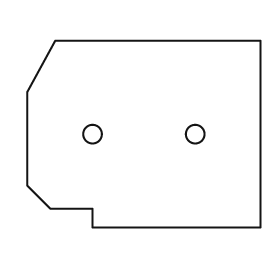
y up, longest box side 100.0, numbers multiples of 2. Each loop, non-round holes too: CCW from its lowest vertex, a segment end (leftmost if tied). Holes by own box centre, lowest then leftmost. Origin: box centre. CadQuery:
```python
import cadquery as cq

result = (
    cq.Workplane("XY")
    .moveTo(-22.0, -40.0)
    .lineTo(50.0, -40.0)
    .lineTo(50.0, 40.0)
    .lineTo(-38.0, 40.0)
    .lineTo(-50.0, 18.0)
    .lineTo(-50.0, -22.0)
    .lineTo(-40.0, -32.0)
    .lineTo(-22.0, -32.0)
    .close()
    .moveTo(-22.0, 0.0)
    .circle(4.0)
    .moveTo(22.0, 0.0)
    .circle(4.0)
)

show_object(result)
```